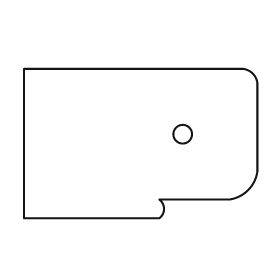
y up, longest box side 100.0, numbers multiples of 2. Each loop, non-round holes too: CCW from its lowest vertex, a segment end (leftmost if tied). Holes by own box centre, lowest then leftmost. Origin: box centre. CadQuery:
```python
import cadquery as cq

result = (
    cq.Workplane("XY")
    .moveTo(-50.0, -32.0)
    .lineTo(8.0, -32.0)
    .threePointArc((10.0, -28.0), (8.0, -24.0))
    .lineTo(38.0, -24.0)
    .threePointArc((46.0, -20.0), (50.0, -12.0))
    .lineTo(50.0, 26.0)
    .threePointArc((48.0, 30.0), (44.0, 32.0))
    .lineTo(-50.0, 32.0)
    .close()
    .moveTo(18.0, 4.0)
    .circle(4.0)
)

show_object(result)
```